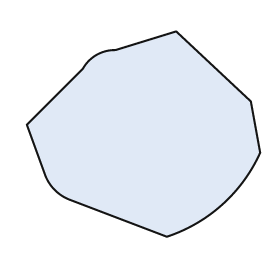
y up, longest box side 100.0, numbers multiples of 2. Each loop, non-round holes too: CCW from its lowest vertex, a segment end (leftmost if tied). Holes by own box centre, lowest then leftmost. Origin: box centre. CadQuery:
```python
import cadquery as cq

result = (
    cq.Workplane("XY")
    .moveTo(10.0, -44.0)
    .threePointArc((34.0, -30.0), (50.0, -8.0))
    .lineTo(46.0, 14.0)
    .lineTo(14.0, 44.0)
    .lineTo(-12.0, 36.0)
    .threePointArc((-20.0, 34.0), (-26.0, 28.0))
    .lineTo(-50.0, 4.0)
    .lineTo(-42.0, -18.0)
    .threePointArc((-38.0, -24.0), (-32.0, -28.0))
    .close()
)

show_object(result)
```